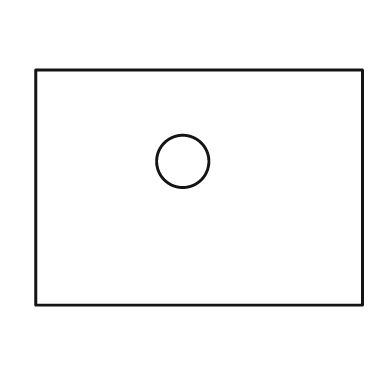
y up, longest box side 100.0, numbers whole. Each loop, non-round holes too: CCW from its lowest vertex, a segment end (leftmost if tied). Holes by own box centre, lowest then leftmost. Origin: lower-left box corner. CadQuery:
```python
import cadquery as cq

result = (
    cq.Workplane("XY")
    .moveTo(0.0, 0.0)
    .lineTo(100.0, 0.0)
    .lineTo(100.0, 72.0)
    .lineTo(0.0, 72.0)
    .close()
    .moveTo(45.0, 44.0)
    .circle(8.0)
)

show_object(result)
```